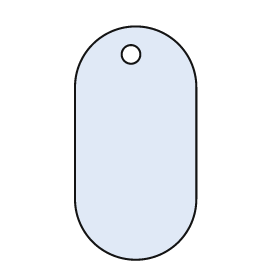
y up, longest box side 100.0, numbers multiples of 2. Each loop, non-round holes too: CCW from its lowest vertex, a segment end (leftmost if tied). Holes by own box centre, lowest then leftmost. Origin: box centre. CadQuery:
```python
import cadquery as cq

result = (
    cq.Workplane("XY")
    .moveTo(-26.0, -24.0)
    .threePointArc((0.0, -50.0), (26.0, -24.0))
    .lineTo(26.0, 24.0)
    .threePointArc((0.0, 50.0), (-26.0, 24.0))
    .close()
    .moveTo(-2.0, 38.0)
    .circle(4.0)
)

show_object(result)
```